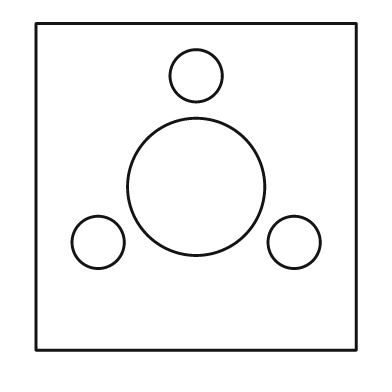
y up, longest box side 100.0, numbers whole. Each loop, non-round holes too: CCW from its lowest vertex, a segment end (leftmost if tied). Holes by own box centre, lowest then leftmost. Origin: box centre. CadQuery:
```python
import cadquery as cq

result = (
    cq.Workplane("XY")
    .moveTo(-49.0, -50.0)
    .lineTo(49.0, -50.0)
    .lineTo(49.0, 50.0)
    .lineTo(-49.0, 50.0)
    .close()
    .moveTo(-30.0, -17.0)
    .circle(8.0)
    .moveTo(30.0, -17.0)
    .circle(8.0)
    .moveTo(0.0, 0.0)
    .circle(21.0)
    .moveTo(0.0, 34.0)
    .circle(8.0)
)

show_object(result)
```